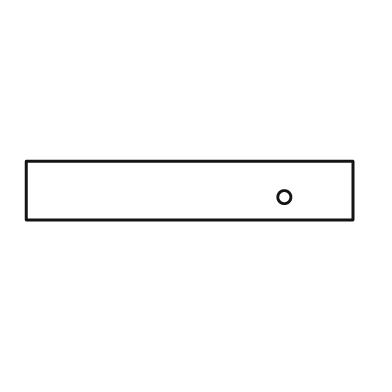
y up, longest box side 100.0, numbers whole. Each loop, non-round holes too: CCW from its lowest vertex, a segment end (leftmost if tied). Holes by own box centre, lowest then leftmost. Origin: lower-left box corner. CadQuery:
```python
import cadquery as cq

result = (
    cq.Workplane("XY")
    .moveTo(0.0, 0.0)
    .lineTo(100.0, 0.0)
    .lineTo(100.0, 18.0)
    .lineTo(0.0, 18.0)
    .close()
    .moveTo(79.0, 7.0)
    .circle(2.0)
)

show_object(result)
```